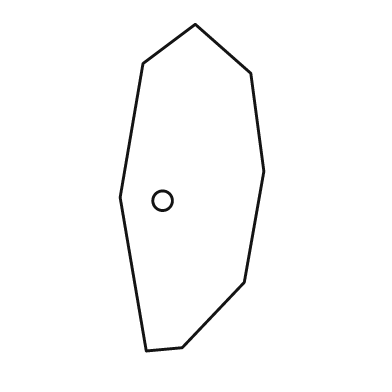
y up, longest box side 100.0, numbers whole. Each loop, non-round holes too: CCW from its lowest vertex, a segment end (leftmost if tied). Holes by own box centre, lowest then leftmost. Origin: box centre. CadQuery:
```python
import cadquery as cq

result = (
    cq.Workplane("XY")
    .moveTo(-14.0, -50.0)
    .lineTo(-3.0, -49.0)
    .lineTo(16.0, -29.0)
    .lineTo(22.0, 5.0)
    .lineTo(18.0, 35.0)
    .lineTo(1.0, 50.0)
    .lineTo(-15.0, 38.0)
    .lineTo(-22.0, -3.0)
    .close()
    .moveTo(-9.0, -4.0)
    .circle(3.0)
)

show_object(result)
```